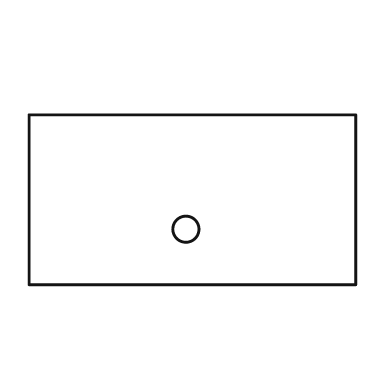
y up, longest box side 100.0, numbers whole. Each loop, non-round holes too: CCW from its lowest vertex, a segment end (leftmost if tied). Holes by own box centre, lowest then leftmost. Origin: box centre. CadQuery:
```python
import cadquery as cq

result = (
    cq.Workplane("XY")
    .moveTo(-50.0, -26.0)
    .lineTo(50.0, -26.0)
    .lineTo(50.0, 26.0)
    .lineTo(-50.0, 26.0)
    .close()
    .moveTo(-2.0, -9.0)
    .circle(4.0)
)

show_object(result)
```